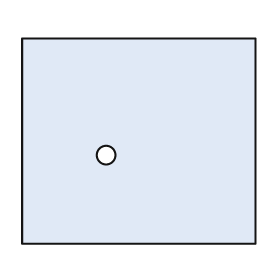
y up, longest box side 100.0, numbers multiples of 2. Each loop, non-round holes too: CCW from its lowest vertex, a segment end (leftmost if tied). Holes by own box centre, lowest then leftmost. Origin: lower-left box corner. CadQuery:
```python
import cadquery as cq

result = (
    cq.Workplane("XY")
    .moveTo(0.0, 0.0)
    .lineTo(100.0, 0.0)
    .lineTo(100.0, 88.0)
    .lineTo(0.0, 88.0)
    .close()
    .moveTo(36.0, 38.0)
    .circle(4.0)
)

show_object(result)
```